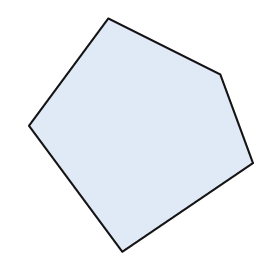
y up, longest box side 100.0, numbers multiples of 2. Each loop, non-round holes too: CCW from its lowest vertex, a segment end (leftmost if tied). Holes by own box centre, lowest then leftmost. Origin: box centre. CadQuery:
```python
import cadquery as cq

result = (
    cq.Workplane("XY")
    .moveTo(-8.0, -50.0)
    .lineTo(48.0, -12.0)
    .lineTo(34.0, 26.0)
    .lineTo(-14.0, 50.0)
    .lineTo(-48.0, 4.0)
    .close()
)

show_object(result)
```